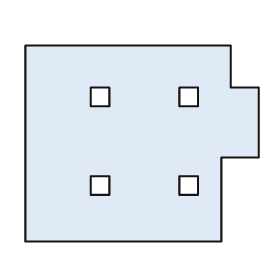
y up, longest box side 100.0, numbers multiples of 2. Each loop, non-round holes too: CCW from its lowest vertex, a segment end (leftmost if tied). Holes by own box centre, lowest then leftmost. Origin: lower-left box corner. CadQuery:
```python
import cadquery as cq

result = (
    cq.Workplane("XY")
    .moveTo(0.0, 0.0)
    .lineTo(84.0, 0.0)
    .lineTo(84.0, 36.0)
    .lineTo(100.0, 36.0)
    .lineTo(100.0, 66.0)
    .lineTo(88.0, 66.0)
    .lineTo(88.0, 84.0)
    .lineTo(0.0, 84.0)
    .close()
    .moveTo(28.0, 20.0)
    .lineTo(36.0, 20.0)
    .lineTo(36.0, 28.0)
    .lineTo(28.0, 28.0)
    .close()
    .moveTo(66.0, 20.0)
    .lineTo(74.0, 20.0)
    .lineTo(74.0, 28.0)
    .lineTo(66.0, 28.0)
    .close()
    .moveTo(28.0, 58.0)
    .lineTo(36.0, 58.0)
    .lineTo(36.0, 66.0)
    .lineTo(28.0, 66.0)
    .close()
    .moveTo(66.0, 58.0)
    .lineTo(74.0, 58.0)
    .lineTo(74.0, 66.0)
    .lineTo(66.0, 66.0)
    .close()
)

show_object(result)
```